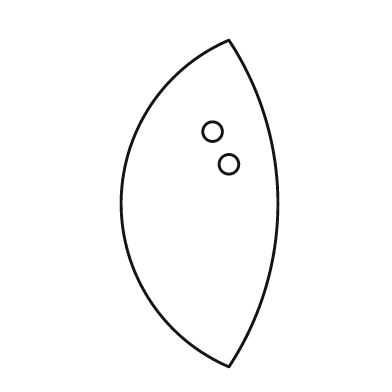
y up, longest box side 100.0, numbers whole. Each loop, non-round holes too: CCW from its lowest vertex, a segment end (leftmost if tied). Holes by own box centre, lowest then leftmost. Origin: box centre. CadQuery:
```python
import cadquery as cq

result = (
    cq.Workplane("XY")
    .moveTo(9.0, -50.0)
    .threePointArc((24.0, 0.0), (9.0, 50.0))
    .threePointArc((-24.0, 0.0), (9.0, -50.0))
    .close()
    .moveTo(9.0, 12.0)
    .circle(3.0)
    .moveTo(4.0, 22.0)
    .circle(3.0)
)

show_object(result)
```